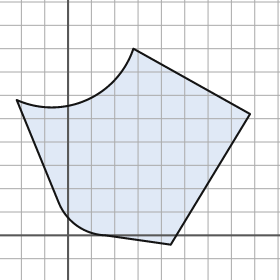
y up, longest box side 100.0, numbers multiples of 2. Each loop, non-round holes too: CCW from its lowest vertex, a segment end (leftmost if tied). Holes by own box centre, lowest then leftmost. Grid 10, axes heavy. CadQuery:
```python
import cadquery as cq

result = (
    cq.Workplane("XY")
    .moveTo(44.0, -4.0)
    .lineTo(78.0, 52.0)
    .lineTo(28.0, 80.0)
    .threePointArc((8.0, 58.0), (-22.0, 58.0))
    .lineTo(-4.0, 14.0)
    .threePointArc((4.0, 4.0), (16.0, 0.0))
    .close()
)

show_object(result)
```